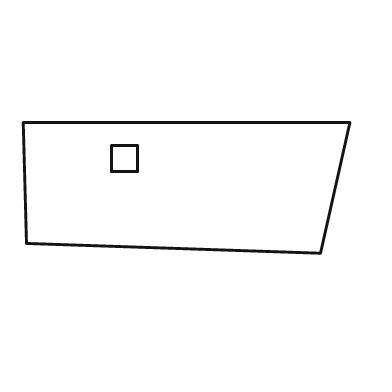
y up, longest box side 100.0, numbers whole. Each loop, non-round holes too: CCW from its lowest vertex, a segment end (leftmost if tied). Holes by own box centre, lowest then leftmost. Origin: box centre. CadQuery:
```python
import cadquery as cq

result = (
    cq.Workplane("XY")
    .moveTo(41.0, -20.0)
    .lineTo(50.0, 20.0)
    .lineTo(-50.0, 20.0)
    .lineTo(-49.0, -17.0)
    .close()
    .moveTo(-23.0, 5.0)
    .lineTo(-15.0, 5.0)
    .lineTo(-15.0, 13.0)
    .lineTo(-23.0, 13.0)
    .close()
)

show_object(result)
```